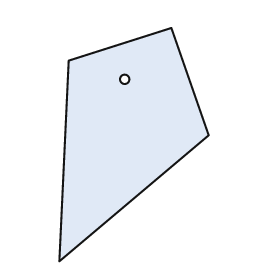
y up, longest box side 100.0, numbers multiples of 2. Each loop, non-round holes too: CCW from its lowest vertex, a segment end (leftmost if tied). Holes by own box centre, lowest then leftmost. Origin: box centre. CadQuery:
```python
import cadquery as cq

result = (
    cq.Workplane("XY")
    .moveTo(-32.0, -50.0)
    .lineTo(32.0, 4.0)
    .lineTo(16.0, 50.0)
    .lineTo(-28.0, 36.0)
    .close()
    .moveTo(-4.0, 28.0)
    .circle(2.0)
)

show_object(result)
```